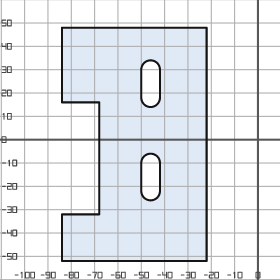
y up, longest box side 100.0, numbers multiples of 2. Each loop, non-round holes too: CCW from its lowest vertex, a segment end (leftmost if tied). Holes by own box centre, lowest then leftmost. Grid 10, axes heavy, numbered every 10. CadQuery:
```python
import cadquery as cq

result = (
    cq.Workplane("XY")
    .moveTo(-84.0, -52.0)
    .lineTo(-22.0, -52.0)
    .lineTo(-22.0, 48.0)
    .lineTo(-84.0, 48.0)
    .lineTo(-84.0, 16.0)
    .lineTo(-68.0, 16.0)
    .lineTo(-68.0, -32.0)
    .lineTo(-84.0, -32.0)
    .close()
    .moveTo(-50.0, -22.0)
    .threePointArc((-46.0, -26.0), (-42.0, -22.0))
    .lineTo(-42.0, -10.0)
    .threePointArc((-46.0, -6.0), (-50.0, -10.0))
    .close()
    .moveTo(-50.0, 18.0)
    .threePointArc((-46.0, 14.0), (-42.0, 18.0))
    .lineTo(-42.0, 30.0)
    .threePointArc((-46.0, 34.0), (-50.0, 30.0))
    .close()
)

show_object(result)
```